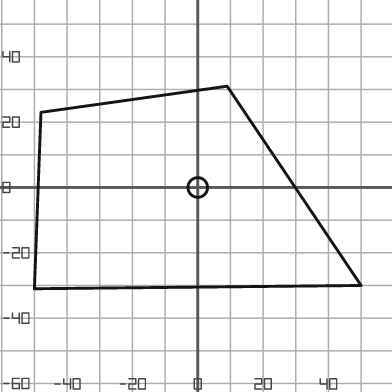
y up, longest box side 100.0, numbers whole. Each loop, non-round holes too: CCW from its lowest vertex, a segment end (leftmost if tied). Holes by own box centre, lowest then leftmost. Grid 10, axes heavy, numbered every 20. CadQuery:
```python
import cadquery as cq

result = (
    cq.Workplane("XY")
    .moveTo(-50.0, -31.0)
    .lineTo(50.0, -30.0)
    .lineTo(9.0, 31.0)
    .lineTo(-48.0, 23.0)
    .close()
    .moveTo(0.0, 0.0)
    .circle(3.0)
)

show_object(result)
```